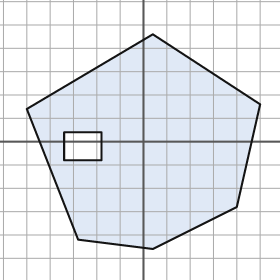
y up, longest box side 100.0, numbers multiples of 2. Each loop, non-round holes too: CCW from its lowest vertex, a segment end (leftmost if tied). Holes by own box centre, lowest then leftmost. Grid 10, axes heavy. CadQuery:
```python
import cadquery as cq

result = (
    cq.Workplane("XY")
    .moveTo(4.0, -46.0)
    .lineTo(40.0, -28.0)
    .lineTo(50.0, 16.0)
    .lineTo(4.0, 46.0)
    .lineTo(-50.0, 14.0)
    .lineTo(-28.0, -42.0)
    .close()
    .moveTo(-34.0, -8.0)
    .lineTo(-18.0, -8.0)
    .lineTo(-18.0, 4.0)
    .lineTo(-34.0, 4.0)
    .close()
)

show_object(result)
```